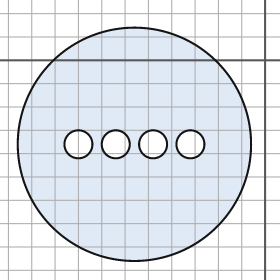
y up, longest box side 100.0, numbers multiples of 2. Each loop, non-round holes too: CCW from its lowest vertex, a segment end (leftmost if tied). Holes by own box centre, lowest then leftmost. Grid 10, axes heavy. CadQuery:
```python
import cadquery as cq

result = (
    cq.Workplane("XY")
    .moveTo(-56.0, -36.0)
    .circle(50.0)
    .moveTo(-80.0, -36.0)
    .circle(6.0)
    .moveTo(-64.0, -36.0)
    .circle(6.0)
    .moveTo(-48.0, -36.0)
    .circle(6.0)
    .moveTo(-32.0, -36.0)
    .circle(6.0)
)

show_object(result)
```